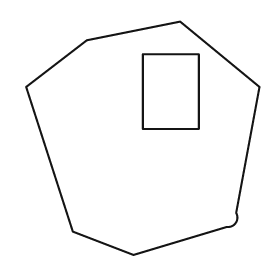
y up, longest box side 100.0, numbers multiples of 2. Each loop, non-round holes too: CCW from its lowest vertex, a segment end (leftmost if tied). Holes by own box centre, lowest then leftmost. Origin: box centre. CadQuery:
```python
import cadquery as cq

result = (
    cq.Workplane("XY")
    .moveTo(-4.0, -50.0)
    .lineTo(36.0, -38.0)
    .threePointArc((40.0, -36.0), (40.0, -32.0))
    .lineTo(50.0, 22.0)
    .lineTo(16.0, 50.0)
    .lineTo(-24.0, 42.0)
    .lineTo(-50.0, 22.0)
    .lineTo(-30.0, -40.0)
    .close()
    .moveTo(0.0, 4.0)
    .lineTo(24.0, 4.0)
    .lineTo(24.0, 36.0)
    .lineTo(0.0, 36.0)
    .close()
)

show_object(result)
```